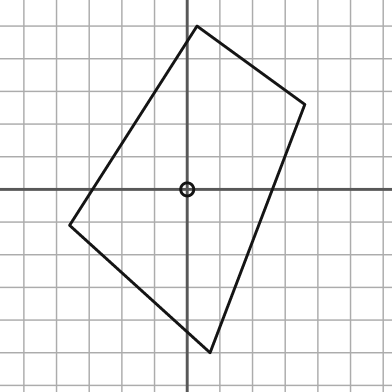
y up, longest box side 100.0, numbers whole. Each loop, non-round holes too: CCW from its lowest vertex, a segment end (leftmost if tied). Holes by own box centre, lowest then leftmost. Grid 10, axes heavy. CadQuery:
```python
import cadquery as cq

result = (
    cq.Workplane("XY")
    .moveTo(7.0, -50.0)
    .lineTo(36.0, 26.0)
    .lineTo(3.0, 50.0)
    .lineTo(-36.0, -11.0)
    .close()
    .moveTo(0.0, 0.0)
    .circle(2.0)
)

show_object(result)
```